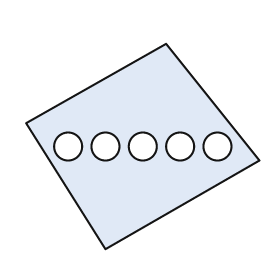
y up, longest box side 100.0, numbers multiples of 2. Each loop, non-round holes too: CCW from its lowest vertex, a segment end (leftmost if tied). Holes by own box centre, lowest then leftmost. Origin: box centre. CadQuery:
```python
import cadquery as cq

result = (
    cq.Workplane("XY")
    .moveTo(-16.0, -44.0)
    .lineTo(50.0, -6.0)
    .lineTo(10.0, 44.0)
    .lineTo(-50.0, 10.0)
    .close()
    .moveTo(-32.0, 0.0)
    .circle(6.0)
    .moveTo(-16.0, 0.0)
    .circle(6.0)
    .moveTo(0.0, 0.0)
    .circle(6.0)
    .moveTo(16.0, 0.0)
    .circle(6.0)
    .moveTo(32.0, 0.0)
    .circle(6.0)
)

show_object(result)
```